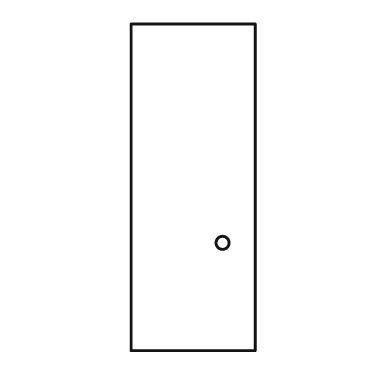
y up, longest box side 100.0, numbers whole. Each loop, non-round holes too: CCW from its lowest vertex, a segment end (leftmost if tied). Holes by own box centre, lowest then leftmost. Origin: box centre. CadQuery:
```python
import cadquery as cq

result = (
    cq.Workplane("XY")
    .moveTo(-19.0, -50.0)
    .lineTo(19.0, -50.0)
    .lineTo(19.0, 50.0)
    .lineTo(-19.0, 50.0)
    .close()
    .moveTo(9.0, -17.0)
    .circle(2.0)
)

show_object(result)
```